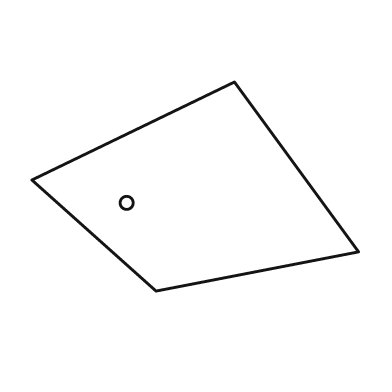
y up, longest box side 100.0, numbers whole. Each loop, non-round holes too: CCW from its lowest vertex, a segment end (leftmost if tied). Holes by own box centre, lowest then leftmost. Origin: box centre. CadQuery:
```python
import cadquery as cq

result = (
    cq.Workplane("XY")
    .moveTo(-12.0, -32.0)
    .lineTo(50.0, -20.0)
    .lineTo(12.0, 32.0)
    .lineTo(-50.0, 2.0)
    .close()
    .moveTo(-21.0, -5.0)
    .circle(2.0)
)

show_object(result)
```